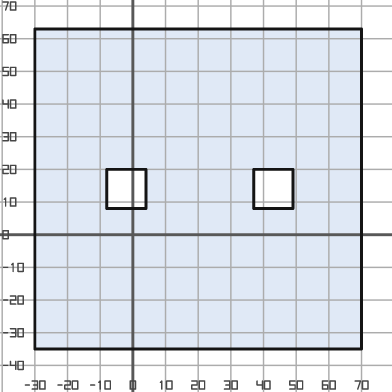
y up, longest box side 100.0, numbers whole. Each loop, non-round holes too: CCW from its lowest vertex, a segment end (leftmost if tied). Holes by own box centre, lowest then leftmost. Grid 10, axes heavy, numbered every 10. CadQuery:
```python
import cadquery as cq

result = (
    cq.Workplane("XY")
    .moveTo(-30.0, -35.0)
    .lineTo(70.0, -35.0)
    .lineTo(70.0, 63.0)
    .lineTo(-30.0, 63.0)
    .close()
    .moveTo(-8.0, 8.0)
    .lineTo(4.0, 8.0)
    .lineTo(4.0, 20.0)
    .lineTo(-8.0, 20.0)
    .close()
    .moveTo(37.0, 8.0)
    .lineTo(49.0, 8.0)
    .lineTo(49.0, 20.0)
    .lineTo(37.0, 20.0)
    .close()
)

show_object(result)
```